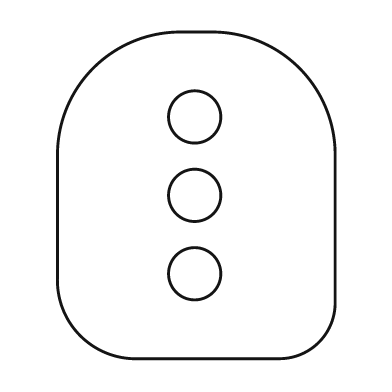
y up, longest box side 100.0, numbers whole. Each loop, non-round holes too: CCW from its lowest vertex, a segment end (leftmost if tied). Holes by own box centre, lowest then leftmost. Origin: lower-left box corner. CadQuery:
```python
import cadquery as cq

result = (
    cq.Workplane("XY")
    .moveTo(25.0, 0.0)
    .lineTo(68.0, 0.0)
    .threePointArc((80.0, 5.0), (85.0, 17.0))
    .lineTo(85.0, 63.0)
    .threePointArc((74.0, 89.0), (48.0, 100.0))
    .lineTo(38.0, 100.0)
    .threePointArc((11.0, 89.0), (0.0, 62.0))
    .lineTo(0.0, 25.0)
    .threePointArc((7.0, 7.0), (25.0, 0.0))
    .close()
    .moveTo(42.0, 26.0)
    .circle(8.0)
    .moveTo(42.0, 50.0)
    .circle(8.0)
    .moveTo(42.0, 74.0)
    .circle(8.0)
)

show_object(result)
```